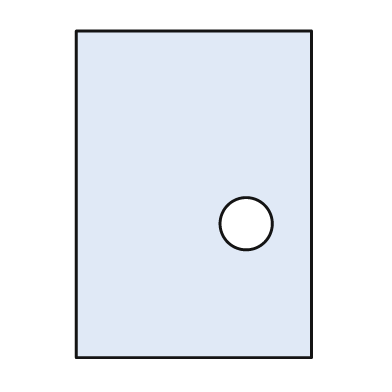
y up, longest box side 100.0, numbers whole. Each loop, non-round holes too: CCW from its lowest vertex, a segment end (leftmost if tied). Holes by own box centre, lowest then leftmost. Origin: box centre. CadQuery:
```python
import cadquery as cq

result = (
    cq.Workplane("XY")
    .moveTo(-36.0, -50.0)
    .lineTo(36.0, -50.0)
    .lineTo(36.0, 50.0)
    .lineTo(-36.0, 50.0)
    .close()
    .moveTo(16.0, -9.0)
    .circle(8.0)
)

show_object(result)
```